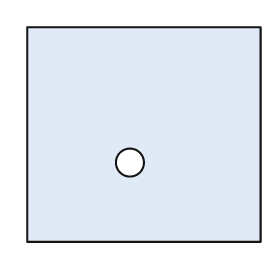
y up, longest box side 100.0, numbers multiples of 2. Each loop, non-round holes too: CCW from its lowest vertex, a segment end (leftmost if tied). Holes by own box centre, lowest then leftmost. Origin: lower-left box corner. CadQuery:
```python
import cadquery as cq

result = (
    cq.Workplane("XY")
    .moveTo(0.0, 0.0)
    .lineTo(100.0, 0.0)
    .lineTo(100.0, 92.0)
    .lineTo(0.0, 92.0)
    .close()
    .moveTo(44.0, 34.0)
    .circle(6.0)
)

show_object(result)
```